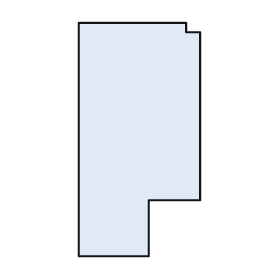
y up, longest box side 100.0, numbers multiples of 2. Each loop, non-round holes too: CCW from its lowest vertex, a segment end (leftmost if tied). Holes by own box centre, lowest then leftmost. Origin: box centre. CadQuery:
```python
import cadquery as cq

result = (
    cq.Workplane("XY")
    .moveTo(-26.0, -50.0)
    .lineTo(4.0, -50.0)
    .lineTo(4.0, -26.0)
    .lineTo(26.0, -26.0)
    .lineTo(26.0, 46.0)
    .lineTo(20.0, 46.0)
    .lineTo(20.0, 50.0)
    .lineTo(-26.0, 50.0)
    .close()
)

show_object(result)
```